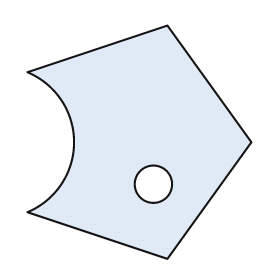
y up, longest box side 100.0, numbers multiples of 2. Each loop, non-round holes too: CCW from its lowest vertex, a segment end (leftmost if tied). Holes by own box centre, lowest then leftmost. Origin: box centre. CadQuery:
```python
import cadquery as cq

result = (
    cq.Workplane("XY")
    .moveTo(12.0, -50.0)
    .lineTo(48.0, 0.0)
    .lineTo(12.0, 50.0)
    .lineTo(-48.0, 30.0)
    .threePointArc((-28.0, 0.0), (-48.0, -30.0))
    .close()
    .moveTo(6.0, -18.0)
    .circle(8.0)
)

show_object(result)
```